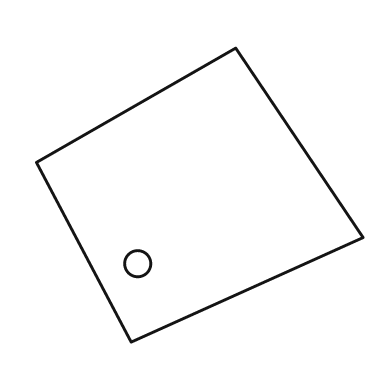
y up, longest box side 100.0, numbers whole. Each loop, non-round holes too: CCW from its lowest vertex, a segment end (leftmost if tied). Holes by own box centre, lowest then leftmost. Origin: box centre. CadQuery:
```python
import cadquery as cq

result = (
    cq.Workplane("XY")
    .moveTo(-21.0, -45.0)
    .lineTo(50.0, -13.0)
    .lineTo(11.0, 45.0)
    .lineTo(-50.0, 10.0)
    .close()
    .moveTo(-19.0, -21.0)
    .circle(4.0)
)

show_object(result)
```